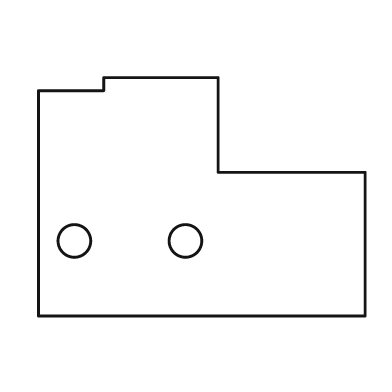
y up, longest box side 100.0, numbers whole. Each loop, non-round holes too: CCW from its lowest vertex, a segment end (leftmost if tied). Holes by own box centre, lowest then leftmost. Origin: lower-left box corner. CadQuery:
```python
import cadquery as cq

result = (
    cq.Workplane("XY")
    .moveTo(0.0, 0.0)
    .lineTo(100.0, 0.0)
    .lineTo(100.0, 44.0)
    .lineTo(55.0, 44.0)
    .lineTo(55.0, 73.0)
    .lineTo(20.0, 73.0)
    .lineTo(20.0, 69.0)
    .lineTo(0.0, 69.0)
    .close()
    .moveTo(11.0, 23.0)
    .circle(5.0)
    .moveTo(45.0, 23.0)
    .circle(5.0)
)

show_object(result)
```